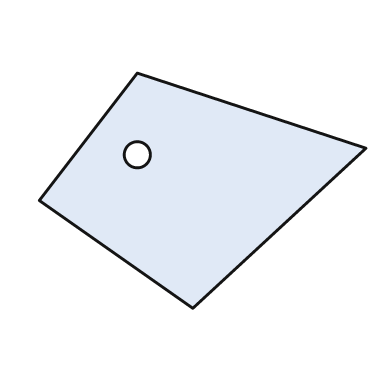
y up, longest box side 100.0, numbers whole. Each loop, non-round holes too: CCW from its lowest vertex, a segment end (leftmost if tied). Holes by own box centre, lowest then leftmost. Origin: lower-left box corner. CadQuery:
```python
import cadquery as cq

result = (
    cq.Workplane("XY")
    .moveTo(47.0, 0.0)
    .lineTo(100.0, 49.0)
    .lineTo(30.0, 72.0)
    .lineTo(0.0, 33.0)
    .close()
    .moveTo(30.0, 47.0)
    .circle(4.0)
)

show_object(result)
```